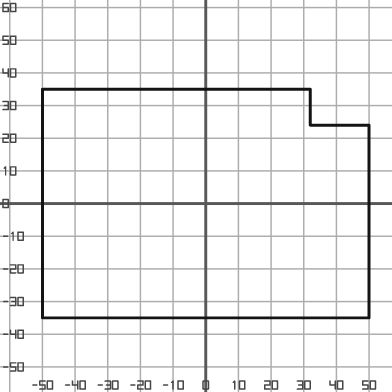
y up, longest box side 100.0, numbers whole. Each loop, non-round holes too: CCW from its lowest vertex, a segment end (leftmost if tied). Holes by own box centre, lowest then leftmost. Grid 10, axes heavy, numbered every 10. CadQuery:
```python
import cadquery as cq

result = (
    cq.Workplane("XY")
    .moveTo(-50.0, -35.0)
    .lineTo(50.0, -35.0)
    .lineTo(50.0, 24.0)
    .lineTo(32.0, 24.0)
    .lineTo(32.0, 35.0)
    .lineTo(-50.0, 35.0)
    .close()
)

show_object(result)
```